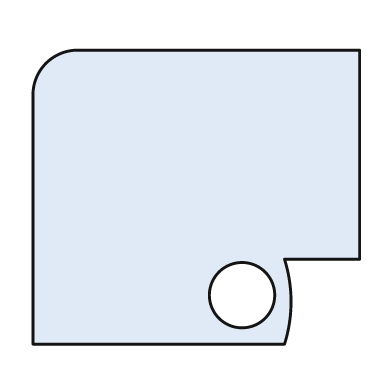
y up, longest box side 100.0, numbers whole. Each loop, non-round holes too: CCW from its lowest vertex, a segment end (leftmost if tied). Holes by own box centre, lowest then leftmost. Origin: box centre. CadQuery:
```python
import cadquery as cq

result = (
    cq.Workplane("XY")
    .moveTo(-50.0, -45.0)
    .lineTo(27.0, -45.0)
    .threePointArc((29.0, -32.0), (27.0, -19.0))
    .lineTo(50.0, -19.0)
    .lineTo(50.0, 45.0)
    .lineTo(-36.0, 45.0)
    .threePointArc((-46.0, 41.0), (-50.0, 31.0))
    .close()
    .moveTo(14.0, -30.0)
    .circle(10.0)
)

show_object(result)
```